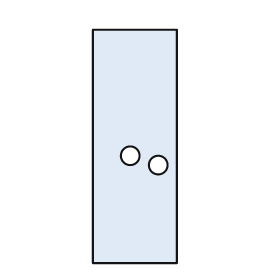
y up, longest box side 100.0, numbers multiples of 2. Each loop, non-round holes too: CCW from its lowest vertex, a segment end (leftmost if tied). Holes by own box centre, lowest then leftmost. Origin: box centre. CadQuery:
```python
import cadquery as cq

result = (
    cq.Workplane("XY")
    .moveTo(-18.0, -50.0)
    .lineTo(18.0, -50.0)
    .lineTo(18.0, 50.0)
    .lineTo(-18.0, 50.0)
    .close()
    .moveTo(10.0, -8.0)
    .circle(4.0)
    .moveTo(-2.0, -4.0)
    .circle(4.0)
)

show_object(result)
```